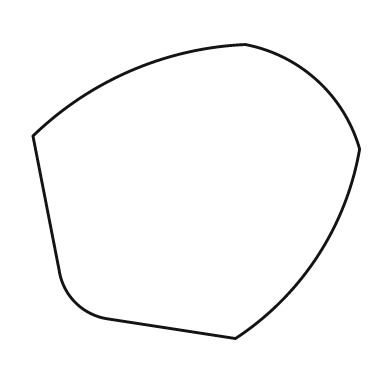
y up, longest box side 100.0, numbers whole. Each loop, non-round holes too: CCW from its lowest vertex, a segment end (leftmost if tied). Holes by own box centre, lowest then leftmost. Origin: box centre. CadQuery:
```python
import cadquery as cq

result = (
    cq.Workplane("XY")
    .moveTo(12.0, -45.0)
    .threePointArc((37.0, -20.0), (50.0, 13.0))
    .threePointArc((37.0, 34.0), (15.0, 45.0))
    .threePointArc((-20.0, 37.0), (-50.0, 17.0))
    .lineTo(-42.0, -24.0)
    .threePointArc((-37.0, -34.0), (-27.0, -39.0))
    .close()
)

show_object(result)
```